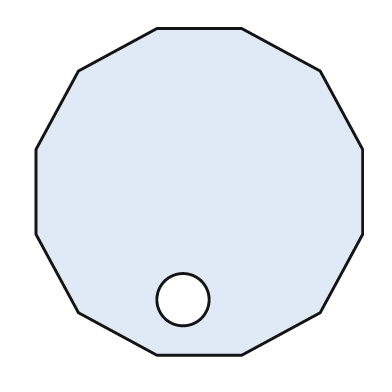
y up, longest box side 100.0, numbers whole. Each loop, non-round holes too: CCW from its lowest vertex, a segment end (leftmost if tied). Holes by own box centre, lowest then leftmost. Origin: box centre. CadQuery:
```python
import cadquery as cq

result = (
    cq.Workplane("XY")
    .moveTo(-13.0, -50.0)
    .lineTo(13.0, -50.0)
    .lineTo(37.0, -37.0)
    .lineTo(50.0, -13.0)
    .lineTo(50.0, 13.0)
    .lineTo(37.0, 37.0)
    .lineTo(13.0, 50.0)
    .lineTo(-13.0, 50.0)
    .lineTo(-37.0, 37.0)
    .lineTo(-50.0, 13.0)
    .lineTo(-50.0, -13.0)
    .lineTo(-37.0, -37.0)
    .close()
    .moveTo(-5.0, -33.0)
    .circle(8.0)
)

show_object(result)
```